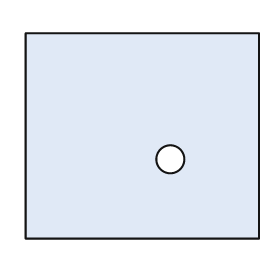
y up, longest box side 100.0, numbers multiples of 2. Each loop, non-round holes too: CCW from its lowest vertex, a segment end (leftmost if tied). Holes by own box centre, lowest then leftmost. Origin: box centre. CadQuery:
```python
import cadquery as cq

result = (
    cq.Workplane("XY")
    .moveTo(-50.0, -44.0)
    .lineTo(50.0, -44.0)
    .lineTo(50.0, 44.0)
    .lineTo(-50.0, 44.0)
    .close()
    .moveTo(12.0, -10.0)
    .circle(6.0)
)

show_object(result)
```